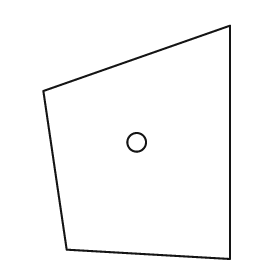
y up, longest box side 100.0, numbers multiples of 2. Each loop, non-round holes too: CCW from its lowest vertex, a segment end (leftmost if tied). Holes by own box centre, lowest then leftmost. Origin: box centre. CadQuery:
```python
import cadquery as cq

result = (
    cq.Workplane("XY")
    .moveTo(40.0, -50.0)
    .lineTo(40.0, 50.0)
    .lineTo(-40.0, 22.0)
    .lineTo(-30.0, -46.0)
    .close()
    .moveTo(0.0, 0.0)
    .circle(4.0)
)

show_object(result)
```